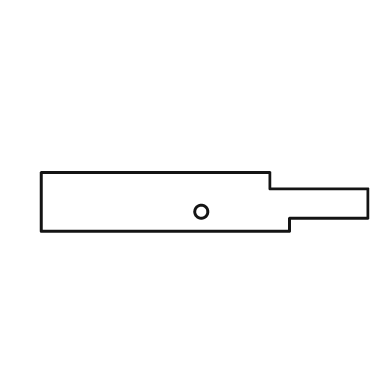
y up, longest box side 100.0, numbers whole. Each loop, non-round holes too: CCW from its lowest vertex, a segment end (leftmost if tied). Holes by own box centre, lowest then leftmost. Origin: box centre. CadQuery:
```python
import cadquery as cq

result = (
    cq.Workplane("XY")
    .moveTo(-50.0, -9.0)
    .lineTo(26.0, -9.0)
    .lineTo(26.0, -5.0)
    .lineTo(50.0, -5.0)
    .lineTo(50.0, 4.0)
    .lineTo(20.0, 4.0)
    .lineTo(20.0, 9.0)
    .lineTo(-50.0, 9.0)
    .close()
    .moveTo(-1.0, -3.0)
    .circle(2.0)
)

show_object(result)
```